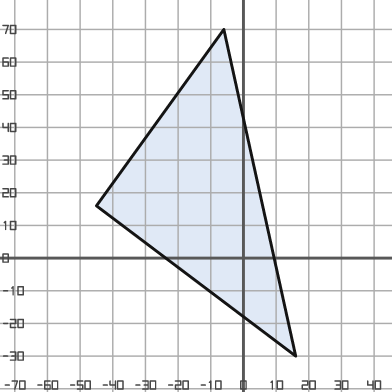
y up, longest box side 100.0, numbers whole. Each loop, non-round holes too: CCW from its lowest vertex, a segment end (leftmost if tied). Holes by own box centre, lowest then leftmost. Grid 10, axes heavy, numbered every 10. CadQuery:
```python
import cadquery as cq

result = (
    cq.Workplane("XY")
    .moveTo(16.0, -30.0)
    .lineTo(-6.0, 70.0)
    .lineTo(-45.0, 16.0)
    .close()
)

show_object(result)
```